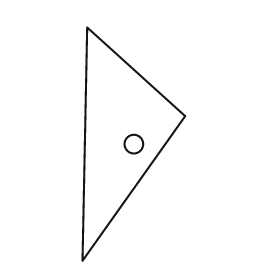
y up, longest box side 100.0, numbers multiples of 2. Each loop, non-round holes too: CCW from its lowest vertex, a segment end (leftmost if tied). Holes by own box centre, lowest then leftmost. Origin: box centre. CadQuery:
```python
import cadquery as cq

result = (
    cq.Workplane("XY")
    .moveTo(-22.0, -50.0)
    .lineTo(22.0, 12.0)
    .lineTo(-20.0, 50.0)
    .close()
    .moveTo(0.0, 0.0)
    .circle(4.0)
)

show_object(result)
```